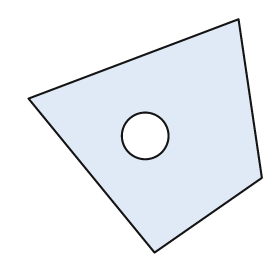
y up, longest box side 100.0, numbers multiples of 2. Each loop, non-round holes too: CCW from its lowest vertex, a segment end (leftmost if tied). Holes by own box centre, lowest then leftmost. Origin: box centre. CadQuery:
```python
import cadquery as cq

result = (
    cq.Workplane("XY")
    .moveTo(4.0, -50.0)
    .lineTo(50.0, -18.0)
    .lineTo(40.0, 50.0)
    .lineTo(-50.0, 16.0)
    .close()
    .moveTo(0.0, 0.0)
    .circle(10.0)
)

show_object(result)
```